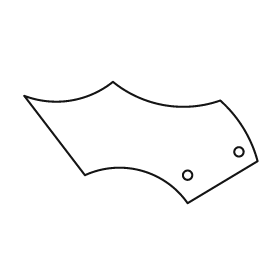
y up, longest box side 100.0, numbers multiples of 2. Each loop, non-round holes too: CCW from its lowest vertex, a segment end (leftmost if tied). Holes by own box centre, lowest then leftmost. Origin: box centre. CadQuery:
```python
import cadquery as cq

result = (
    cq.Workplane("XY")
    .moveTo(20.0, -26.0)
    .lineTo(50.0, -8.0)
    .threePointArc((44.0, 6.0), (34.0, 18.0))
    .threePointArc((10.0, 16.0), (-12.0, 26.0))
    .threePointArc((-30.0, 18.0), (-50.0, 20.0))
    .lineTo(-24.0, -14.0)
    .threePointArc((0.0, -12.0), (20.0, -26.0))
    .close()
    .moveTo(20.0, -14.0)
    .circle(2.0)
    .moveTo(42.0, -4.0)
    .circle(2.0)
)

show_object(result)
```